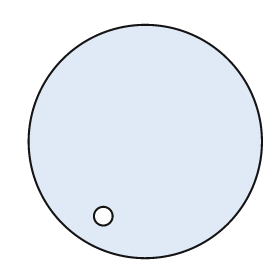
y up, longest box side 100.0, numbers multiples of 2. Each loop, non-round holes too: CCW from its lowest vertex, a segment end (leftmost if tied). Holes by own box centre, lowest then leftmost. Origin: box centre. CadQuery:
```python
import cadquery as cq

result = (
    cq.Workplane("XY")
    .moveTo(0.0, 0.0)
    .circle(50.0)
    .moveTo(-18.0, -32.0)
    .circle(4.0)
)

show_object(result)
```